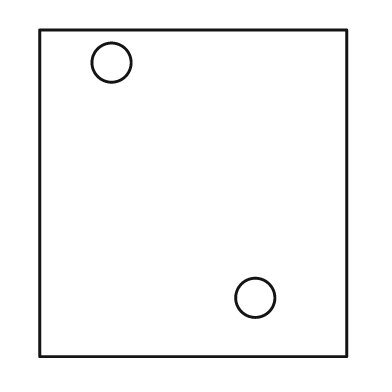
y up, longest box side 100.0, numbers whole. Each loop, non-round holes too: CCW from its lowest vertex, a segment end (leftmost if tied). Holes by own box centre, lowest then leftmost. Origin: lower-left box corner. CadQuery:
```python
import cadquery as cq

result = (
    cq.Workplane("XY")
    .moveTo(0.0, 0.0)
    .lineTo(94.0, 0.0)
    .lineTo(94.0, 100.0)
    .lineTo(0.0, 100.0)
    .close()
    .moveTo(66.0, 18.0)
    .circle(6.0)
    .moveTo(22.0, 90.0)
    .circle(6.0)
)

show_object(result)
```